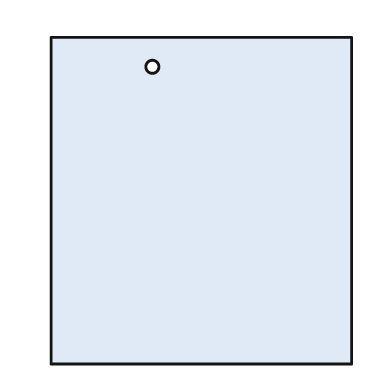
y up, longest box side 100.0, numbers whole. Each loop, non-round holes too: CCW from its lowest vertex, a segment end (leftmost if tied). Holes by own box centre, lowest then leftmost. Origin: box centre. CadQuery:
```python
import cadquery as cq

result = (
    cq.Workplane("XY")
    .moveTo(-46.0, -50.0)
    .lineTo(46.0, -50.0)
    .lineTo(46.0, 50.0)
    .lineTo(-46.0, 50.0)
    .close()
    .moveTo(-15.0, 41.0)
    .circle(2.0)
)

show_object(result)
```